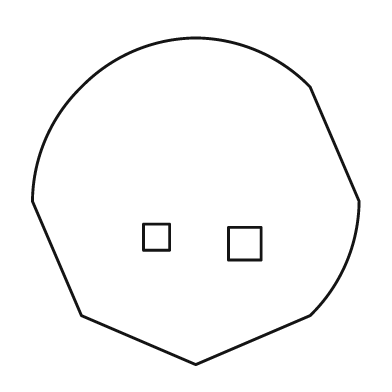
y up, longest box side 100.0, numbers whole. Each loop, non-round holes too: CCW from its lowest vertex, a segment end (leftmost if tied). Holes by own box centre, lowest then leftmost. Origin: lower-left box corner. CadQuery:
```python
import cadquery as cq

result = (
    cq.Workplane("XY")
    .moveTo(50.0, 0.0)
    .lineTo(85.0, 15.0)
    .threePointArc((96.0, 31.0), (100.0, 50.0))
    .lineTo(85.0, 85.0)
    .threePointArc((69.0, 96.0), (50.0, 100.0))
    .threePointArc((31.0, 96.0), (15.0, 85.0))
    .threePointArc((4.0, 69.0), (0.0, 50.0))
    .lineTo(15.0, 15.0)
    .close()
    .moveTo(60.0, 32.0)
    .lineTo(70.0, 32.0)
    .lineTo(70.0, 42.0)
    .lineTo(60.0, 42.0)
    .close()
    .moveTo(34.0, 35.0)
    .lineTo(42.0, 35.0)
    .lineTo(42.0, 43.0)
    .lineTo(34.0, 43.0)
    .close()
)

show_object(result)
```